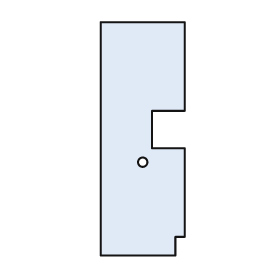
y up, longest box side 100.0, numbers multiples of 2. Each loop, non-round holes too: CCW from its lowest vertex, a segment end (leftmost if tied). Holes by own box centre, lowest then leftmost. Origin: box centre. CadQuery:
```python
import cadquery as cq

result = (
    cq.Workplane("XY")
    .moveTo(-18.0, -50.0)
    .lineTo(14.0, -50.0)
    .lineTo(14.0, -42.0)
    .lineTo(18.0, -42.0)
    .lineTo(18.0, -4.0)
    .lineTo(4.0, -4.0)
    .lineTo(4.0, 12.0)
    .lineTo(18.0, 12.0)
    .lineTo(18.0, 50.0)
    .lineTo(-18.0, 50.0)
    .close()
    .moveTo(0.0, -10.0)
    .circle(2.0)
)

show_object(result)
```